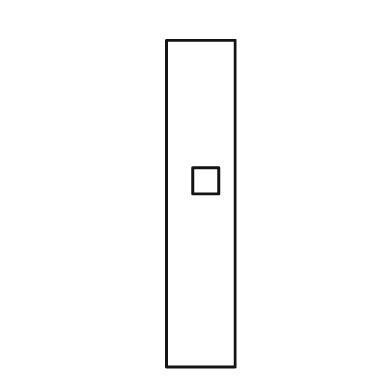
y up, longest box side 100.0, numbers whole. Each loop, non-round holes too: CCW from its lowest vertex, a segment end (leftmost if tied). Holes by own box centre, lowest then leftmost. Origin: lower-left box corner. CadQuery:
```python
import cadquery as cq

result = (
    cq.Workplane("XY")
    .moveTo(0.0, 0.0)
    .lineTo(21.0, 0.0)
    .lineTo(21.0, 100.0)
    .lineTo(0.0, 100.0)
    .close()
    .moveTo(8.0, 53.0)
    .lineTo(16.0, 53.0)
    .lineTo(16.0, 61.0)
    .lineTo(8.0, 61.0)
    .close()
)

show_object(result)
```